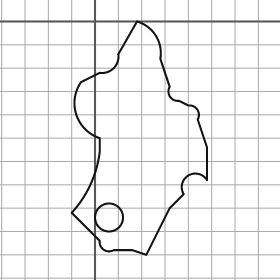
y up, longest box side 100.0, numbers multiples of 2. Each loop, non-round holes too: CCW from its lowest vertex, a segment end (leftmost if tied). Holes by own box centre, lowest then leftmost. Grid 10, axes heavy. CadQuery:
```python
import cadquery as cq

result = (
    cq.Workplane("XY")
    .moveTo(22.0, -100.0)
    .lineTo(32.0, -80.0)
    .lineTo(38.0, -74.0)
    .threePointArc((40.0, -66.0), (48.0, -68.0))
    .lineTo(48.0, -54.0)
    .lineTo(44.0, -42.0)
    .threePointArc((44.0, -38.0), (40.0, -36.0))
    .lineTo(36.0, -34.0)
    .threePointArc((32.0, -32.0), (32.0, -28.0))
    .lineTo(28.0, -16.0)
    .threePointArc((26.0, -6.0), (18.0, 0.0))
    .lineTo(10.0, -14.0)
    .threePointArc((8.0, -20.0), (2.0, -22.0))
    .lineTo(-6.0, -26.0)
    .threePointArc((-8.0, -40.0), (2.0, -50.0))
    .lineTo(2.0, -56.0)
    .threePointArc((-2.0, -70.0), (-10.0, -82.0))
    .lineTo(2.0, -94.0)
    .threePointArc((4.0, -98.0), (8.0, -98.0))
    .lineTo(16.0, -98.0)
    .close()
    .moveTo(6.0, -84.0)
    .circle(6.0)
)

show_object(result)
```